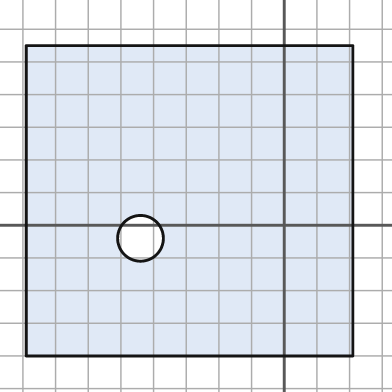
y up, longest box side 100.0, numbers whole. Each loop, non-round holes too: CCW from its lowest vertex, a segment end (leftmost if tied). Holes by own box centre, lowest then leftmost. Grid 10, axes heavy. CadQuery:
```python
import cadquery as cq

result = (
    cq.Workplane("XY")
    .moveTo(-79.0, -40.0)
    .lineTo(21.0, -40.0)
    .lineTo(21.0, 55.0)
    .lineTo(-79.0, 55.0)
    .close()
    .moveTo(-44.0, -4.0)
    .circle(7.0)
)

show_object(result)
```